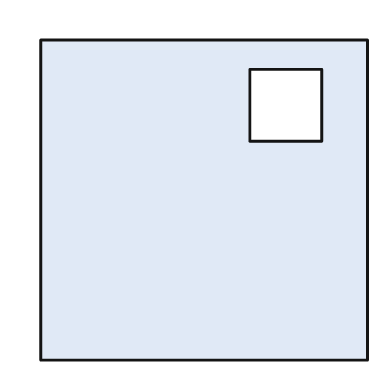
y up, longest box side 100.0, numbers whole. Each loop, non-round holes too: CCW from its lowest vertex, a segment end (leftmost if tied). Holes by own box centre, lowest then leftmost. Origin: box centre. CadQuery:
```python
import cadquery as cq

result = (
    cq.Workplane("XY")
    .moveTo(-50.0, -49.0)
    .lineTo(50.0, -49.0)
    .lineTo(50.0, 49.0)
    .lineTo(-50.0, 49.0)
    .close()
    .moveTo(14.0, 18.0)
    .lineTo(36.0, 18.0)
    .lineTo(36.0, 40.0)
    .lineTo(14.0, 40.0)
    .close()
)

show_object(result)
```